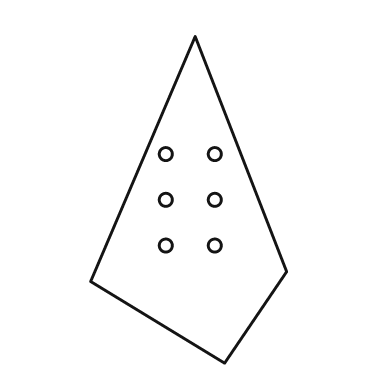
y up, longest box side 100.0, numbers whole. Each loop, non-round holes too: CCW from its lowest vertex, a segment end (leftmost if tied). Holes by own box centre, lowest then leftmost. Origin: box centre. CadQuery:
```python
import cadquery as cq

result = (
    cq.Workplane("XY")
    .moveTo(11.0, -50.0)
    .lineTo(30.0, -22.0)
    .lineTo(2.0, 50.0)
    .lineTo(-30.0, -25.0)
    .close()
    .moveTo(-7.0, -14.0)
    .circle(2.0)
    .moveTo(8.0, -14.0)
    .circle(2.0)
    .moveTo(-7.0, 0.0)
    .circle(2.0)
    .moveTo(8.0, 0.0)
    .circle(2.0)
    .moveTo(-7.0, 14.0)
    .circle(2.0)
    .moveTo(8.0, 14.0)
    .circle(2.0)
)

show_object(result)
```